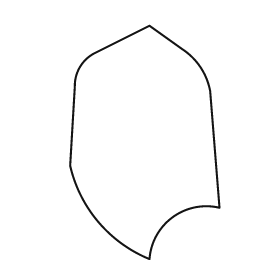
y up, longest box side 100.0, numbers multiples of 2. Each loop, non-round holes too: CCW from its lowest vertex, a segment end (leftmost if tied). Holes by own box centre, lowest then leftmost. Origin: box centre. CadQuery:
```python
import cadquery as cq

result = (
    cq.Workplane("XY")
    .moveTo(2.0, -50.0)
    .threePointArc((12.0, -32.0), (32.0, -28.0))
    .lineTo(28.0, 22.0)
    .threePointArc((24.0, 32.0), (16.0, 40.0))
    .lineTo(2.0, 50.0)
    .lineTo(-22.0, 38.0)
    .threePointArc((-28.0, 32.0), (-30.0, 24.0))
    .lineTo(-32.0, -10.0)
    .threePointArc((-20.0, -34.0), (2.0, -50.0))
    .close()
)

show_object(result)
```